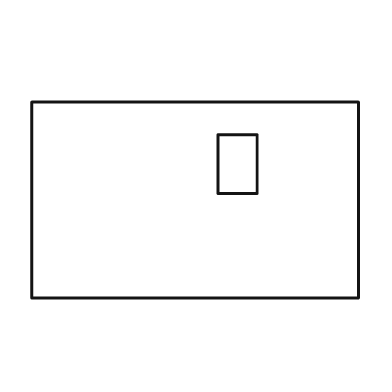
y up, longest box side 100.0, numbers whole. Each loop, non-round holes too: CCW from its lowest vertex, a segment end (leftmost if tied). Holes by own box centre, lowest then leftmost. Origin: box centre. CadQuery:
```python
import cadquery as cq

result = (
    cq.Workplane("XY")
    .moveTo(-50.0, -30.0)
    .lineTo(50.0, -30.0)
    .lineTo(50.0, 30.0)
    .lineTo(-50.0, 30.0)
    .close()
    .moveTo(7.0, 2.0)
    .lineTo(19.0, 2.0)
    .lineTo(19.0, 20.0)
    .lineTo(7.0, 20.0)
    .close()
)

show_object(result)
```